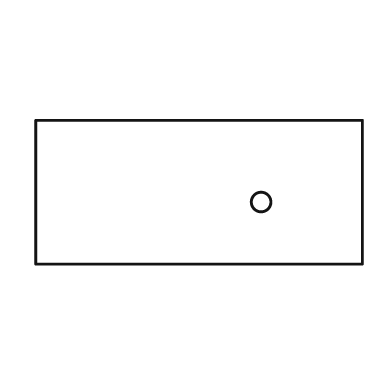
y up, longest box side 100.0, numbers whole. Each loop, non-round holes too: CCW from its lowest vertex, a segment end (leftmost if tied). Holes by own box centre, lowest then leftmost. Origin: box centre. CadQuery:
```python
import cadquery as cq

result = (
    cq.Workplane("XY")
    .moveTo(-50.0, -22.0)
    .lineTo(50.0, -22.0)
    .lineTo(50.0, 22.0)
    .lineTo(-50.0, 22.0)
    .close()
    .moveTo(19.0, -3.0)
    .circle(3.0)
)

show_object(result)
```